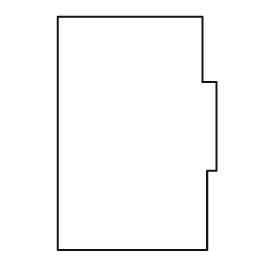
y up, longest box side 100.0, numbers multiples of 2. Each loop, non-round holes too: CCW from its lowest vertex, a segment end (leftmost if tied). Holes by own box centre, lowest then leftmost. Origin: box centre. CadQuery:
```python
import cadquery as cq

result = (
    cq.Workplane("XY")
    .moveTo(-34.0, -50.0)
    .lineTo(30.0, -50.0)
    .lineTo(30.0, -16.0)
    .lineTo(34.0, -16.0)
    .lineTo(34.0, 22.0)
    .lineTo(28.0, 22.0)
    .lineTo(28.0, 50.0)
    .lineTo(-34.0, 50.0)
    .close()
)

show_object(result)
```